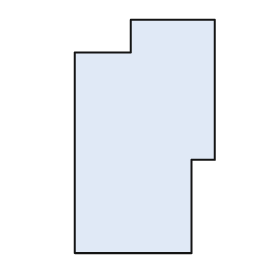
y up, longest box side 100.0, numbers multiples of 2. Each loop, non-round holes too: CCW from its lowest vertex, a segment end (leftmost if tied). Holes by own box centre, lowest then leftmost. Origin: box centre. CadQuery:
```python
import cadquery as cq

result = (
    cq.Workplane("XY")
    .moveTo(-30.0, -50.0)
    .lineTo(20.0, -50.0)
    .lineTo(20.0, -10.0)
    .lineTo(30.0, -10.0)
    .lineTo(30.0, 50.0)
    .lineTo(-6.0, 50.0)
    .lineTo(-6.0, 36.0)
    .lineTo(-30.0, 36.0)
    .close()
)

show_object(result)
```